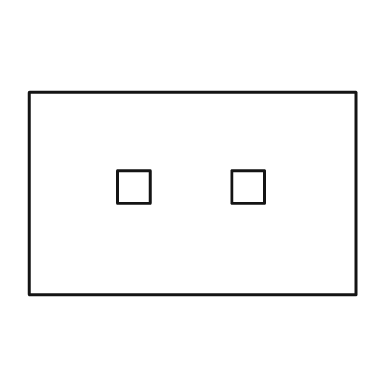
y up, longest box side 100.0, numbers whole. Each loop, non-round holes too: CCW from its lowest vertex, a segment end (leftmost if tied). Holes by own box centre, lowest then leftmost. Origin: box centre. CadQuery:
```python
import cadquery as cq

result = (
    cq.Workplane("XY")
    .moveTo(-50.0, -31.0)
    .lineTo(50.0, -31.0)
    .lineTo(50.0, 31.0)
    .lineTo(-50.0, 31.0)
    .close()
    .moveTo(-23.0, -3.0)
    .lineTo(-13.0, -3.0)
    .lineTo(-13.0, 7.0)
    .lineTo(-23.0, 7.0)
    .close()
    .moveTo(12.0, -3.0)
    .lineTo(22.0, -3.0)
    .lineTo(22.0, 7.0)
    .lineTo(12.0, 7.0)
    .close()
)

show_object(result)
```